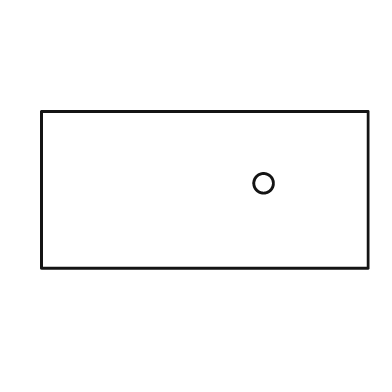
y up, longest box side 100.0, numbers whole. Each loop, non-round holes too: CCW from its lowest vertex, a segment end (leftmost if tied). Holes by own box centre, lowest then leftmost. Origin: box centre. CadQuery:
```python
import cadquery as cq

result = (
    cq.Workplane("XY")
    .moveTo(-50.0, -24.0)
    .lineTo(50.0, -24.0)
    .lineTo(50.0, 24.0)
    .lineTo(-50.0, 24.0)
    .close()
    .moveTo(18.0, 2.0)
    .circle(3.0)
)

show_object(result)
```